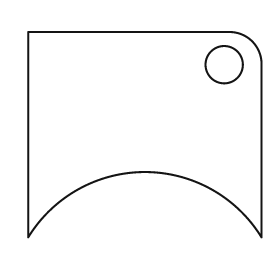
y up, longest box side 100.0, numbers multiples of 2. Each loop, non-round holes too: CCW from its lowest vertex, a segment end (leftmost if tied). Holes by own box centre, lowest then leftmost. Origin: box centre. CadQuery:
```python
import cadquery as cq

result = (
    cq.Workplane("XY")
    .moveTo(-50.0, -44.0)
    .threePointArc((0.0, -16.0), (50.0, -44.0))
    .lineTo(50.0, 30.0)
    .threePointArc((46.0, 40.0), (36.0, 44.0))
    .lineTo(-50.0, 44.0)
    .close()
    .moveTo(34.0, 30.0)
    .circle(8.0)
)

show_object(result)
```